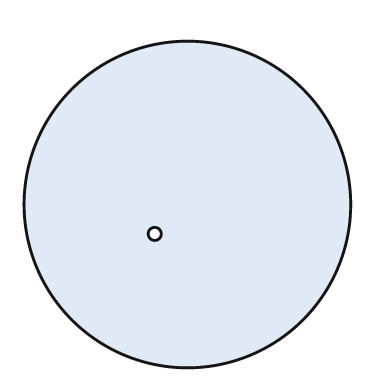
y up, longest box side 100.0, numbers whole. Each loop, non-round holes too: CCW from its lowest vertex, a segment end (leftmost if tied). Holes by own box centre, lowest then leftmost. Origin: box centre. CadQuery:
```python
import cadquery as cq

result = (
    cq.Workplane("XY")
    .moveTo(0.0, 0.0)
    .circle(50.0)
    .moveTo(-10.0, -9.0)
    .circle(2.0)
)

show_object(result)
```